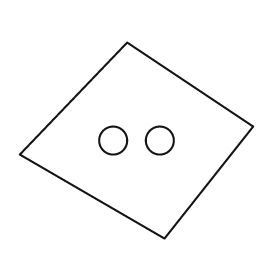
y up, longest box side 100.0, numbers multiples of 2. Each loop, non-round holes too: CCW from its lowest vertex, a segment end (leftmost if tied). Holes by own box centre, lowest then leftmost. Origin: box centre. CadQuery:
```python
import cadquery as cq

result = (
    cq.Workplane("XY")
    .moveTo(12.0, -42.0)
    .lineTo(50.0, 6.0)
    .lineTo(-4.0, 42.0)
    .lineTo(-50.0, -6.0)
    .close()
    .moveTo(-10.0, 0.0)
    .circle(6.0)
    .moveTo(10.0, 0.0)
    .circle(6.0)
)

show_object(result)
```